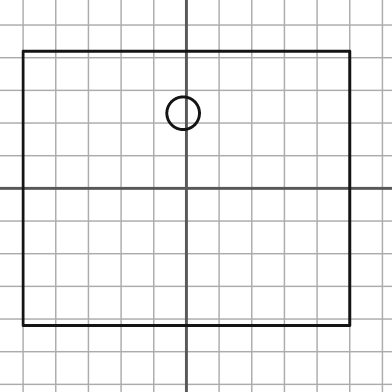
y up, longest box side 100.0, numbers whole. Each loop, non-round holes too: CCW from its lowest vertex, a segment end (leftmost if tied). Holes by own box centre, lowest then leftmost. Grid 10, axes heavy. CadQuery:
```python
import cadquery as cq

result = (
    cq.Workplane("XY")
    .moveTo(-50.0, -42.0)
    .lineTo(50.0, -42.0)
    .lineTo(50.0, 42.0)
    .lineTo(-50.0, 42.0)
    .close()
    .moveTo(-1.0, 23.0)
    .circle(5.0)
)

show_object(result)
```